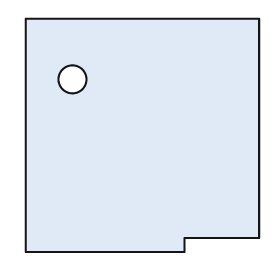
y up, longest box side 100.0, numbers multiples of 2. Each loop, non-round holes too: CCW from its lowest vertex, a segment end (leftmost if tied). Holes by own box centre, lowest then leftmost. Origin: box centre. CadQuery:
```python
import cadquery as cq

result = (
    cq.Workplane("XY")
    .moveTo(-50.0, -50.0)
    .lineTo(18.0, -50.0)
    .lineTo(18.0, -44.0)
    .lineTo(50.0, -44.0)
    .lineTo(50.0, 50.0)
    .lineTo(-50.0, 50.0)
    .close()
    .moveTo(-30.0, 24.0)
    .circle(6.0)
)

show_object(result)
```